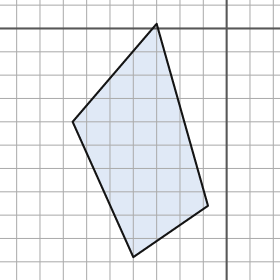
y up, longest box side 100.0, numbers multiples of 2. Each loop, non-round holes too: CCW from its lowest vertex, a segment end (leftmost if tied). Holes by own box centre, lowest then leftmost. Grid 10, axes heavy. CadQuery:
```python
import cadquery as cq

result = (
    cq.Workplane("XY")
    .moveTo(-40.0, -98.0)
    .lineTo(-8.0, -76.0)
    .lineTo(-30.0, 2.0)
    .lineTo(-66.0, -40.0)
    .close()
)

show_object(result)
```